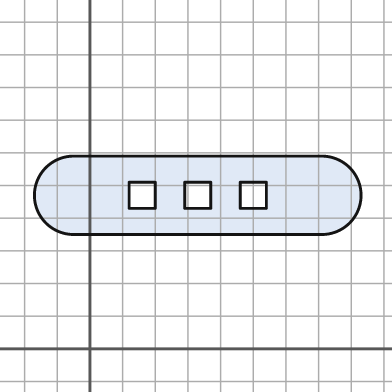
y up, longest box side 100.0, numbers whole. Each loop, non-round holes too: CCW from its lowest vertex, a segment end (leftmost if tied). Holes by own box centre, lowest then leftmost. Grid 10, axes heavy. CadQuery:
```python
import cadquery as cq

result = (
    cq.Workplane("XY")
    .moveTo(-5.0, 35.0)
    .lineTo(71.0, 35.0)
    .threePointArc((83.0, 47.0), (71.0, 59.0))
    .lineTo(-5.0, 59.0)
    .threePointArc((-17.0, 47.0), (-5.0, 35.0))
    .close()
    .moveTo(12.0, 43.0)
    .lineTo(20.0, 43.0)
    .lineTo(20.0, 51.0)
    .lineTo(12.0, 51.0)
    .close()
    .moveTo(29.0, 43.0)
    .lineTo(37.0, 43.0)
    .lineTo(37.0, 51.0)
    .lineTo(29.0, 51.0)
    .close()
    .moveTo(46.0, 43.0)
    .lineTo(54.0, 43.0)
    .lineTo(54.0, 51.0)
    .lineTo(46.0, 51.0)
    .close()
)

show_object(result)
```